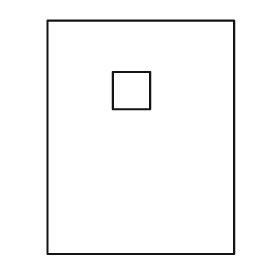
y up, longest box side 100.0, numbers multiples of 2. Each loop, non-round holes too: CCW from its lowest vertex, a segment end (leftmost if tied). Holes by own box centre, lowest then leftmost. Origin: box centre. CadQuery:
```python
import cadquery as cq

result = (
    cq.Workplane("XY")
    .moveTo(-40.0, -50.0)
    .lineTo(40.0, -50.0)
    .lineTo(40.0, 50.0)
    .lineTo(-40.0, 50.0)
    .close()
    .moveTo(-12.0, 12.0)
    .lineTo(4.0, 12.0)
    .lineTo(4.0, 28.0)
    .lineTo(-12.0, 28.0)
    .close()
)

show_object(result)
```